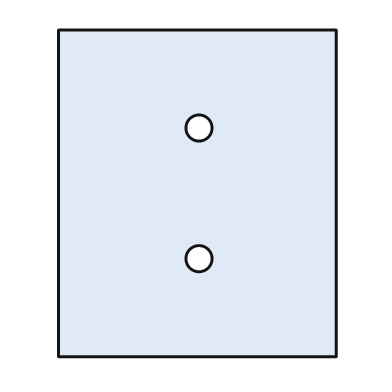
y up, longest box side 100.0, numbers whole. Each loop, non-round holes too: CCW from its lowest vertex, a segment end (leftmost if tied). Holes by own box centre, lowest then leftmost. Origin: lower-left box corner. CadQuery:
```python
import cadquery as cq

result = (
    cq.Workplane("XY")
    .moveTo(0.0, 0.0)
    .lineTo(85.0, 0.0)
    .lineTo(85.0, 100.0)
    .lineTo(0.0, 100.0)
    .close()
    .moveTo(43.0, 30.0)
    .circle(4.0)
    .moveTo(43.0, 70.0)
    .circle(4.0)
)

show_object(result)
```